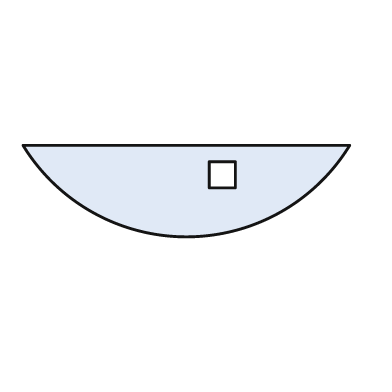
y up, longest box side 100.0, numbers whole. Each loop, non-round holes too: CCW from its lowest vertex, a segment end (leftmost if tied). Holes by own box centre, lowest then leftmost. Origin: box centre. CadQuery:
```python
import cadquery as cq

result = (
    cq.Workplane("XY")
    .moveTo(-50.0, 14.0)
    .threePointArc((0.0, -14.0), (50.0, 14.0))
    .close()
    .moveTo(7.0, 1.0)
    .lineTo(15.0, 1.0)
    .lineTo(15.0, 9.0)
    .lineTo(7.0, 9.0)
    .close()
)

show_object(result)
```